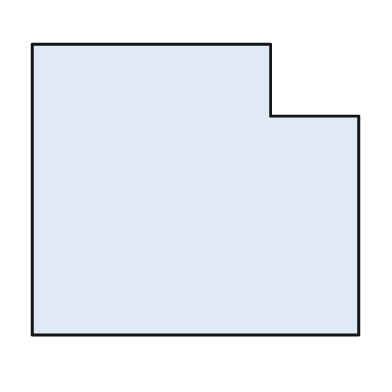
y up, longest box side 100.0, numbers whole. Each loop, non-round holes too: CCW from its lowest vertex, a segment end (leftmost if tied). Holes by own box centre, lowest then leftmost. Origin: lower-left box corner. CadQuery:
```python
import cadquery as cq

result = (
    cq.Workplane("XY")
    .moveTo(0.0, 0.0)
    .lineTo(100.0, 0.0)
    .lineTo(100.0, 67.0)
    .lineTo(73.0, 67.0)
    .lineTo(73.0, 89.0)
    .lineTo(0.0, 89.0)
    .close()
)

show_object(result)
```